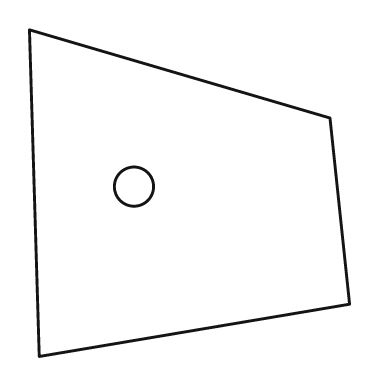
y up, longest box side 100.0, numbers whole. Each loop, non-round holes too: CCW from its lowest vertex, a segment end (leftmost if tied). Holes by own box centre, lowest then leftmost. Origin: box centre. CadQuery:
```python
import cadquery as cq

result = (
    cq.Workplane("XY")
    .moveTo(-46.0, -50.0)
    .lineTo(49.0, -34.0)
    .lineTo(43.0, 23.0)
    .lineTo(-49.0, 50.0)
    .close()
    .moveTo(-17.0, 2.0)
    .circle(6.0)
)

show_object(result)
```